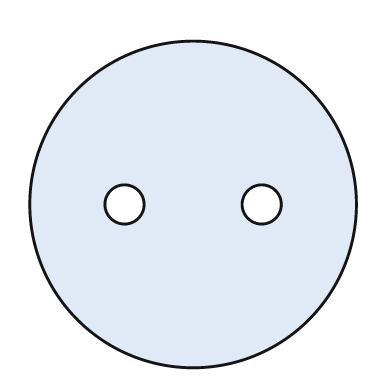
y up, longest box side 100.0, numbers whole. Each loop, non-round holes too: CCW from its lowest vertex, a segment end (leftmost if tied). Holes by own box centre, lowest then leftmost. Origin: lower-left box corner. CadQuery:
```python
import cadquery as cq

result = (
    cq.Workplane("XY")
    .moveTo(50.0, 50.0)
    .circle(50.0)
    .moveTo(29.0, 50.0)
    .circle(6.0)
    .moveTo(71.0, 50.0)
    .circle(6.0)
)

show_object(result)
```